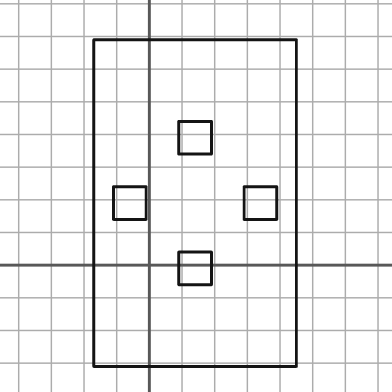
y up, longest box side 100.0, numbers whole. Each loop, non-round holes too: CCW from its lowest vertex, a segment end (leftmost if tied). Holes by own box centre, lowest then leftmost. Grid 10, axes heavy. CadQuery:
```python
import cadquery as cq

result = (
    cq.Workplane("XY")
    .moveTo(-17.0, -31.0)
    .lineTo(45.0, -31.0)
    .lineTo(45.0, 69.0)
    .lineTo(-17.0, 69.0)
    .close()
    .moveTo(9.0, -6.0)
    .lineTo(19.0, -6.0)
    .lineTo(19.0, 4.0)
    .lineTo(9.0, 4.0)
    .close()
    .moveTo(-11.0, 14.0)
    .lineTo(-1.0, 14.0)
    .lineTo(-1.0, 24.0)
    .lineTo(-11.0, 24.0)
    .close()
    .moveTo(29.0, 14.0)
    .lineTo(39.0, 14.0)
    .lineTo(39.0, 24.0)
    .lineTo(29.0, 24.0)
    .close()
    .moveTo(9.0, 34.0)
    .lineTo(19.0, 34.0)
    .lineTo(19.0, 44.0)
    .lineTo(9.0, 44.0)
    .close()
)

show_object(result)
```